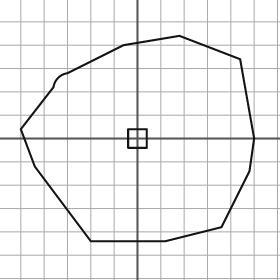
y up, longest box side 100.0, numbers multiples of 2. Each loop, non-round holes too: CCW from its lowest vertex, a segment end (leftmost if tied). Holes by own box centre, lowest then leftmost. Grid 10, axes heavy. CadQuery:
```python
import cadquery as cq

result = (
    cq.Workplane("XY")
    .moveTo(-20.0, -44.0)
    .lineTo(12.0, -44.0)
    .lineTo(36.0, -38.0)
    .lineTo(48.0, -14.0)
    .lineTo(50.0, 0.0)
    .lineTo(44.0, 34.0)
    .lineTo(18.0, 44.0)
    .lineTo(-6.0, 40.0)
    .lineTo(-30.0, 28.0)
    .threePointArc((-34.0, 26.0), (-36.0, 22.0))
    .lineTo(-50.0, 4.0)
    .lineTo(-44.0, -12.0)
    .close()
    .moveTo(-4.0, -4.0)
    .lineTo(4.0, -4.0)
    .lineTo(4.0, 4.0)
    .lineTo(-4.0, 4.0)
    .close()
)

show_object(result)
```